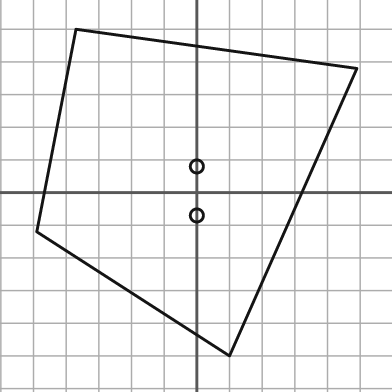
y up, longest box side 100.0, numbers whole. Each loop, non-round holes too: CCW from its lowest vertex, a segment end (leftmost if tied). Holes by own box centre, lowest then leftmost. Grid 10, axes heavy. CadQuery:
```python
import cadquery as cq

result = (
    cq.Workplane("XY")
    .moveTo(10.0, -50.0)
    .lineTo(49.0, 38.0)
    .lineTo(-37.0, 50.0)
    .lineTo(-49.0, -12.0)
    .close()
    .moveTo(0.0, -7.0)
    .circle(2.0)
    .moveTo(0.0, 8.0)
    .circle(2.0)
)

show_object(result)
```